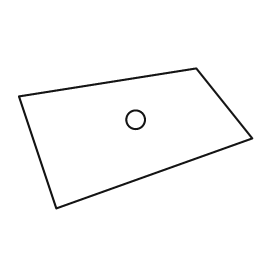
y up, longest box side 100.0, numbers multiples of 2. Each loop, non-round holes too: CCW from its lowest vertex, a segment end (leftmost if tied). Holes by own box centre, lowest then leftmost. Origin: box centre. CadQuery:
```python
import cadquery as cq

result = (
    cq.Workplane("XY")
    .moveTo(-34.0, -30.0)
    .lineTo(50.0, 0.0)
    .lineTo(26.0, 30.0)
    .lineTo(-50.0, 18.0)
    .close()
    .moveTo(0.0, 8.0)
    .circle(4.0)
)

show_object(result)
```